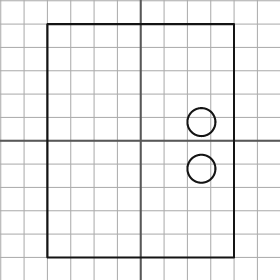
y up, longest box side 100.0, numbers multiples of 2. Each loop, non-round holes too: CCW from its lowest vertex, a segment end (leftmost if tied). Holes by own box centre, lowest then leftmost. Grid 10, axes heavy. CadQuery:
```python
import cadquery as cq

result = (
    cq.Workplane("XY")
    .moveTo(-40.0, -50.0)
    .lineTo(40.0, -50.0)
    .lineTo(40.0, 50.0)
    .lineTo(-40.0, 50.0)
    .close()
    .moveTo(26.0, -12.0)
    .circle(6.0)
    .moveTo(26.0, 8.0)
    .circle(6.0)
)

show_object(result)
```